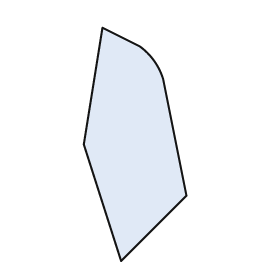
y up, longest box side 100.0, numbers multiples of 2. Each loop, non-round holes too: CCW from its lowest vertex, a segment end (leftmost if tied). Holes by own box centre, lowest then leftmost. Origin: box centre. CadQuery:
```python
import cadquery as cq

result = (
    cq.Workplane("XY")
    .moveTo(-6.0, -50.0)
    .lineTo(22.0, -22.0)
    .lineTo(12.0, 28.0)
    .threePointArc((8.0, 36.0), (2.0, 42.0))
    .lineTo(-14.0, 50.0)
    .lineTo(-22.0, 0.0)
    .close()
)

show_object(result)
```